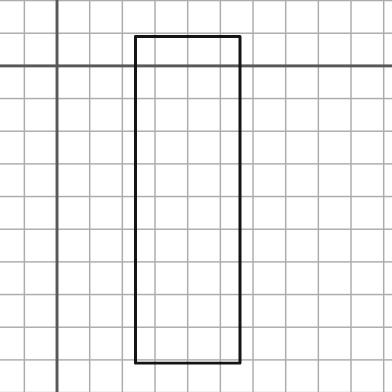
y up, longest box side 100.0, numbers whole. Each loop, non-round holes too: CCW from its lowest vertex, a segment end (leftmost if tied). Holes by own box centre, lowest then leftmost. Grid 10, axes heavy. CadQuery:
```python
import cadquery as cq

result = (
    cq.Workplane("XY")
    .moveTo(24.0, -91.0)
    .lineTo(56.0, -91.0)
    .lineTo(56.0, 9.0)
    .lineTo(24.0, 9.0)
    .close()
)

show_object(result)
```